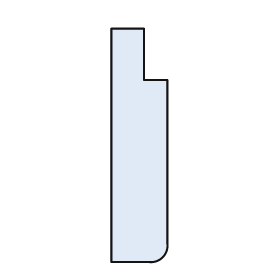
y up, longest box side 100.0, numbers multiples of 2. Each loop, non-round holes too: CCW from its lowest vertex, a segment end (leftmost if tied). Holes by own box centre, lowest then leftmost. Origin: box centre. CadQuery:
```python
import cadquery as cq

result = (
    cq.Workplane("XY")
    .moveTo(-12.0, -50.0)
    .lineTo(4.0, -50.0)
    .threePointArc((10.0, -48.0), (12.0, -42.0))
    .lineTo(12.0, 28.0)
    .lineTo(2.0, 28.0)
    .lineTo(2.0, 50.0)
    .lineTo(-12.0, 50.0)
    .close()
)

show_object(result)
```